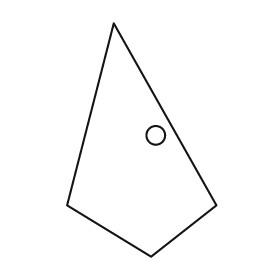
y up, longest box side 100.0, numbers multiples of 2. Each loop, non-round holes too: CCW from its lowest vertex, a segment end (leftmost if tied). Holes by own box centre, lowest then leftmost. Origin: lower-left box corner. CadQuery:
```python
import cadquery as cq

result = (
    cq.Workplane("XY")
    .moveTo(36.0, 0.0)
    .lineTo(64.0, 22.0)
    .lineTo(20.0, 100.0)
    .lineTo(0.0, 22.0)
    .close()
    .moveTo(38.0, 52.0)
    .circle(4.0)
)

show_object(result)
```